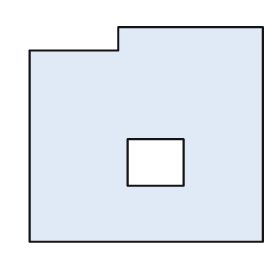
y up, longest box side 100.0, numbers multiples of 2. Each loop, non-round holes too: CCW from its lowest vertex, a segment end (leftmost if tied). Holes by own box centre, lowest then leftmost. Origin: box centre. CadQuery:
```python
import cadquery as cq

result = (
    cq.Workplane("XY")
    .moveTo(-50.0, -46.0)
    .lineTo(50.0, -46.0)
    .lineTo(50.0, 46.0)
    .lineTo(-12.0, 46.0)
    .lineTo(-12.0, 36.0)
    .lineTo(-50.0, 36.0)
    .close()
    .moveTo(-8.0, -22.0)
    .lineTo(16.0, -22.0)
    .lineTo(16.0, -2.0)
    .lineTo(-8.0, -2.0)
    .close()
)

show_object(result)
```